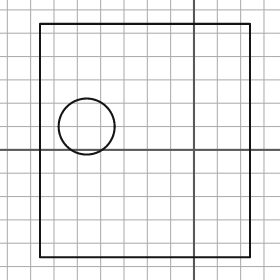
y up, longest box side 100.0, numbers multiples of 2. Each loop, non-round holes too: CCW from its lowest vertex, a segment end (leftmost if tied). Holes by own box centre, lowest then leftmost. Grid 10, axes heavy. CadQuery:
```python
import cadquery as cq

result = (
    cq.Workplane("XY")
    .moveTo(-66.0, -46.0)
    .lineTo(24.0, -46.0)
    .lineTo(24.0, 54.0)
    .lineTo(-66.0, 54.0)
    .close()
    .moveTo(-46.0, 10.0)
    .circle(12.0)
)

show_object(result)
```